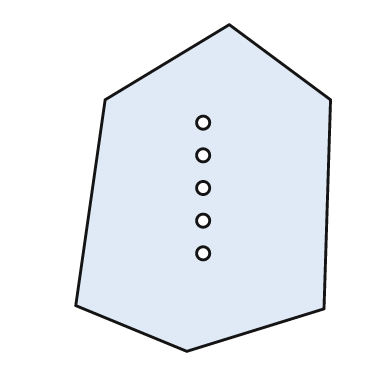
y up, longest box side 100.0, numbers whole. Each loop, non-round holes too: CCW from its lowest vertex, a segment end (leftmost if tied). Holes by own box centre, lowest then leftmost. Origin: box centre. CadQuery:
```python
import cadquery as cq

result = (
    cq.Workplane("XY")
    .moveTo(-5.0, -50.0)
    .lineTo(37.0, -37.0)
    .lineTo(39.0, 27.0)
    .lineTo(8.0, 50.0)
    .lineTo(-30.0, 27.0)
    .lineTo(-39.0, -36.0)
    .close()
    .moveTo(0.0, -20.0)
    .circle(2.0)
    .moveTo(0.0, -10.0)
    .circle(2.0)
    .moveTo(0.0, 0.0)
    .circle(2.0)
    .moveTo(0.0, 10.0)
    .circle(2.0)
    .moveTo(0.0, 20.0)
    .circle(2.0)
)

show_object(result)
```